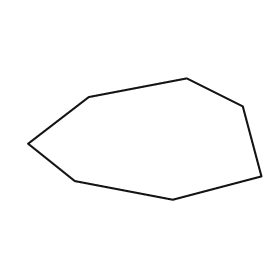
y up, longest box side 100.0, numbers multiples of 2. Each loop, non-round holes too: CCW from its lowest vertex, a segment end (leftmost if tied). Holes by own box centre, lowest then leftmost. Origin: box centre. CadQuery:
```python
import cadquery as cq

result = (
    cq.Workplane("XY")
    .moveTo(12.0, -26.0)
    .lineTo(50.0, -16.0)
    .lineTo(42.0, 14.0)
    .lineTo(18.0, 26.0)
    .lineTo(-24.0, 18.0)
    .lineTo(-50.0, -2.0)
    .lineTo(-30.0, -18.0)
    .close()
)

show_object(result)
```